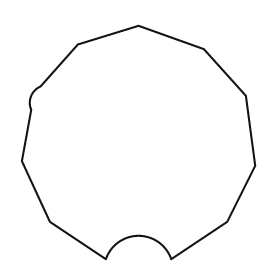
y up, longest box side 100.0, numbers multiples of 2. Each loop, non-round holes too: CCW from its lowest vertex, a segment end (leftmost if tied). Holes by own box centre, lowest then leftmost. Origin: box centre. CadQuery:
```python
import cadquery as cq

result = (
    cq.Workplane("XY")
    .moveTo(-14.0, -50.0)
    .threePointArc((0.0, -40.0), (14.0, -50.0))
    .lineTo(38.0, -34.0)
    .lineTo(50.0, -10.0)
    .lineTo(46.0, 20.0)
    .lineTo(28.0, 40.0)
    .lineTo(0.0, 50.0)
    .lineTo(-26.0, 42.0)
    .lineTo(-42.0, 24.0)
    .threePointArc((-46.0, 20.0), (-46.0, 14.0))
    .lineTo(-50.0, -8.0)
    .lineTo(-38.0, -34.0)
    .close()
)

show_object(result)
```